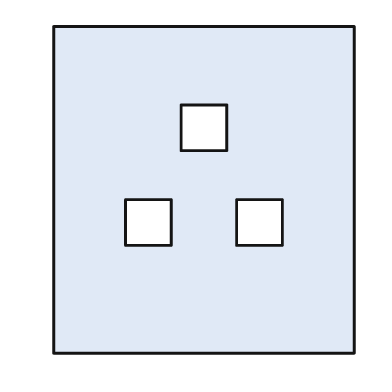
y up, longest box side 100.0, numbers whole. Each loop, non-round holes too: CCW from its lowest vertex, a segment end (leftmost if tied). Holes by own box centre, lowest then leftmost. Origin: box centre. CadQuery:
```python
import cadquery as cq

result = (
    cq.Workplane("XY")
    .moveTo(-46.0, -50.0)
    .lineTo(46.0, -50.0)
    .lineTo(46.0, 50.0)
    .lineTo(-46.0, 50.0)
    .close()
    .moveTo(-24.0, -17.0)
    .lineTo(-10.0, -17.0)
    .lineTo(-10.0, -3.0)
    .lineTo(-24.0, -3.0)
    .close()
    .moveTo(10.0, -17.0)
    .lineTo(24.0, -17.0)
    .lineTo(24.0, -3.0)
    .lineTo(10.0, -3.0)
    .close()
    .moveTo(-7.0, 12.0)
    .lineTo(7.0, 12.0)
    .lineTo(7.0, 26.0)
    .lineTo(-7.0, 26.0)
    .close()
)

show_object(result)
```